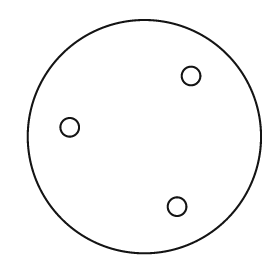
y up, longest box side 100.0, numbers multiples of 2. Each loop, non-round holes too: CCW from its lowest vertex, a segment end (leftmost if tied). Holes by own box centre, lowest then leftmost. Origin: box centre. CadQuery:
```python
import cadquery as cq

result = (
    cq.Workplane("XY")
    .moveTo(0.0, 0.0)
    .circle(50.0)
    .moveTo(14.0, -30.0)
    .circle(4.0)
    .moveTo(-32.0, 4.0)
    .circle(4.0)
    .moveTo(20.0, 26.0)
    .circle(4.0)
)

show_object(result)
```